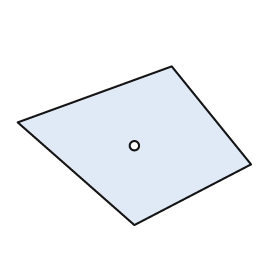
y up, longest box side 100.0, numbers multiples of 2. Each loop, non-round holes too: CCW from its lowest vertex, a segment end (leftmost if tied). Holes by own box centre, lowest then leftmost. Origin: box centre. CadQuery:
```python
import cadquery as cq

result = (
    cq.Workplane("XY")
    .moveTo(0.0, -34.0)
    .lineTo(50.0, -8.0)
    .lineTo(16.0, 34.0)
    .lineTo(-50.0, 10.0)
    .close()
    .moveTo(0.0, 0.0)
    .circle(2.0)
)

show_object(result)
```